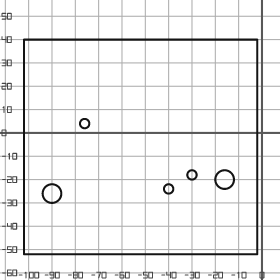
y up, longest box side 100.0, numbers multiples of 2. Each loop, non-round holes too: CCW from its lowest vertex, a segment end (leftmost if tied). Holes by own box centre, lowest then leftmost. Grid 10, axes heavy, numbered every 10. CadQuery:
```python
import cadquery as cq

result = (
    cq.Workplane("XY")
    .moveTo(-102.0, -52.0)
    .lineTo(-2.0, -52.0)
    .lineTo(-2.0, 40.0)
    .lineTo(-102.0, 40.0)
    .close()
    .moveTo(-90.0, -26.0)
    .circle(4.0)
    .moveTo(-40.0, -24.0)
    .circle(2.0)
    .moveTo(-16.0, -20.0)
    .circle(4.0)
    .moveTo(-30.0, -18.0)
    .circle(2.0)
    .moveTo(-76.0, 4.0)
    .circle(2.0)
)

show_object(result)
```